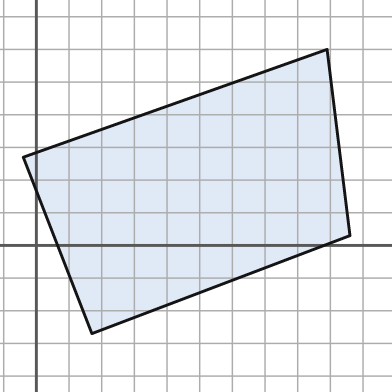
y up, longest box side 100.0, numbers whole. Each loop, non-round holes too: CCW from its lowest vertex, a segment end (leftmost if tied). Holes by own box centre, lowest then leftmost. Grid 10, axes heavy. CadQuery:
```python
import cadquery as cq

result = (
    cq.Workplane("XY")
    .moveTo(17.0, -27.0)
    .lineTo(96.0, 3.0)
    .lineTo(89.0, 60.0)
    .lineTo(-4.0, 27.0)
    .close()
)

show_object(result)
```